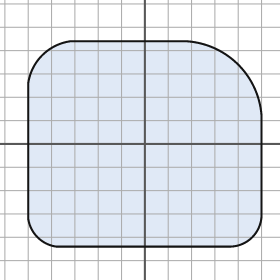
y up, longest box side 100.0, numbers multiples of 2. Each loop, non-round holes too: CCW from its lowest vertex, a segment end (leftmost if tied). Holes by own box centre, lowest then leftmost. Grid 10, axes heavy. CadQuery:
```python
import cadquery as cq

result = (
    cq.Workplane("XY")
    .moveTo(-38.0, -44.0)
    .lineTo(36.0, -44.0)
    .threePointArc((46.0, -40.0), (50.0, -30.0))
    .lineTo(50.0, 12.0)
    .threePointArc((40.0, 34.0), (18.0, 44.0))
    .lineTo(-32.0, 44.0)
    .threePointArc((-44.0, 38.0), (-50.0, 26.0))
    .lineTo(-50.0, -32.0)
    .threePointArc((-46.0, -40.0), (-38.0, -44.0))
    .close()
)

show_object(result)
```